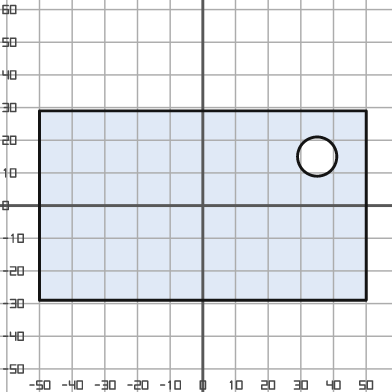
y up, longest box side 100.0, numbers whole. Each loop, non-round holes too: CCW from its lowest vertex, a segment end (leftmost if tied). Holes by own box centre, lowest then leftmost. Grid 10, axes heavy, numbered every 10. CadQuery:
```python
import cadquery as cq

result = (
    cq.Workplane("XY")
    .moveTo(-50.0, -29.0)
    .lineTo(50.0, -29.0)
    .lineTo(50.0, 29.0)
    .lineTo(-50.0, 29.0)
    .close()
    .moveTo(35.0, 15.0)
    .circle(6.0)
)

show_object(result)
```